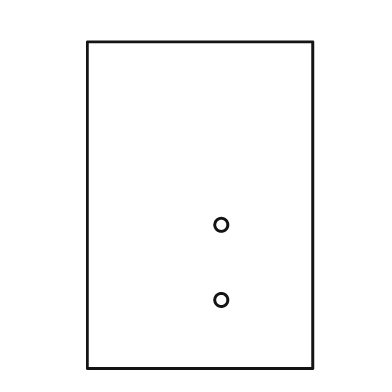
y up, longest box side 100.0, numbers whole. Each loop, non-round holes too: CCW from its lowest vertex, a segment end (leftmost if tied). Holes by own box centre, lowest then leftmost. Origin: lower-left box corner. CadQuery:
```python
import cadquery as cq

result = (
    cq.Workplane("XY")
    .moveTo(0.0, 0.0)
    .lineTo(69.0, 0.0)
    .lineTo(69.0, 100.0)
    .lineTo(0.0, 100.0)
    .close()
    .moveTo(41.0, 21.0)
    .circle(2.0)
    .moveTo(41.0, 44.0)
    .circle(2.0)
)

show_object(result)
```